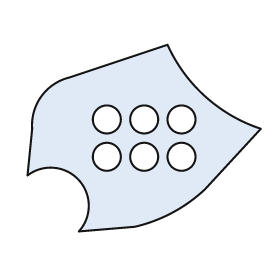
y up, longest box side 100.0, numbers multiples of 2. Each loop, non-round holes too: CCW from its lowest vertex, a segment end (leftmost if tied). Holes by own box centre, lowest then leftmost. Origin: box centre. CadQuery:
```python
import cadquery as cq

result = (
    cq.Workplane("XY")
    .moveTo(-28.0, -40.0)
    .lineTo(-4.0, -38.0)
    .threePointArc((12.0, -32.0), (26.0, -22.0))
    .lineTo(50.0, 4.0)
    .threePointArc((26.0, 18.0), (10.0, 40.0))
    .lineTo(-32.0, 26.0)
    .threePointArc((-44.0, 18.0), (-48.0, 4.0))
    .lineTo(-50.0, -16.0)
    .threePointArc((-28.0, -18.0), (-28.0, -40.0))
    .close()
    .moveTo(-16.0, -8.0)
    .circle(6.0)
    .moveTo(0.0, -8.0)
    .circle(6.0)
    .moveTo(16.0, -8.0)
    .circle(6.0)
    .moveTo(-16.0, 8.0)
    .circle(6.0)
    .moveTo(0.0, 8.0)
    .circle(6.0)
    .moveTo(16.0, 8.0)
    .circle(6.0)
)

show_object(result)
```